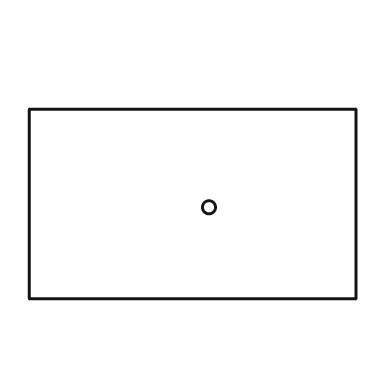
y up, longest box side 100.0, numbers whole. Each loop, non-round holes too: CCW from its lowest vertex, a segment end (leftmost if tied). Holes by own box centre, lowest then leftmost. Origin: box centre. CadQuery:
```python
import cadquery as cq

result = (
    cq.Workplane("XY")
    .moveTo(-50.0, -29.0)
    .lineTo(50.0, -29.0)
    .lineTo(50.0, 29.0)
    .lineTo(-50.0, 29.0)
    .close()
    .moveTo(5.0, -1.0)
    .circle(2.0)
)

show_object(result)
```